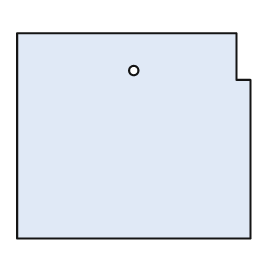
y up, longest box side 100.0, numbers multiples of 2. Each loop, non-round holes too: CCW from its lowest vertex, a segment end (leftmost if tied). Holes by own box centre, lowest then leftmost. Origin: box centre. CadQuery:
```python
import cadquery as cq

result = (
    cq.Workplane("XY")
    .moveTo(-50.0, -44.0)
    .lineTo(50.0, -44.0)
    .lineTo(50.0, 24.0)
    .lineTo(44.0, 24.0)
    .lineTo(44.0, 44.0)
    .lineTo(-50.0, 44.0)
    .close()
    .moveTo(0.0, 28.0)
    .circle(2.0)
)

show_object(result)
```